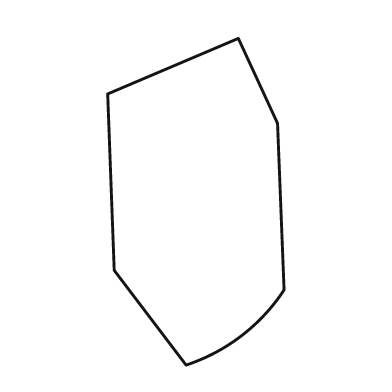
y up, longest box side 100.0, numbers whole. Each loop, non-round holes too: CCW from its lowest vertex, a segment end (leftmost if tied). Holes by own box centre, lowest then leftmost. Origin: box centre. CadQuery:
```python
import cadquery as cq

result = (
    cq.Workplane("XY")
    .moveTo(-3.0, -50.0)
    .threePointArc((14.0, -41.0), (27.0, -27.0))
    .lineTo(25.0, 24.0)
    .lineTo(13.0, 50.0)
    .lineTo(-27.0, 33.0)
    .lineTo(-25.0, -21.0)
    .close()
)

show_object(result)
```